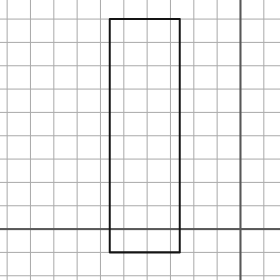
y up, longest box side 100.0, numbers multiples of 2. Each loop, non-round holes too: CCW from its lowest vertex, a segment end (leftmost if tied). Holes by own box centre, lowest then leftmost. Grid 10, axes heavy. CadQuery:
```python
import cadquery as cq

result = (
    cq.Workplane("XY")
    .moveTo(-56.0, -10.0)
    .lineTo(-26.0, -10.0)
    .lineTo(-26.0, 90.0)
    .lineTo(-56.0, 90.0)
    .close()
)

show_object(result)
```